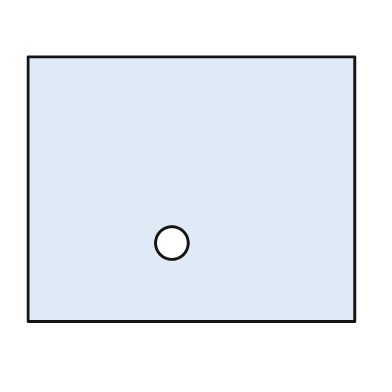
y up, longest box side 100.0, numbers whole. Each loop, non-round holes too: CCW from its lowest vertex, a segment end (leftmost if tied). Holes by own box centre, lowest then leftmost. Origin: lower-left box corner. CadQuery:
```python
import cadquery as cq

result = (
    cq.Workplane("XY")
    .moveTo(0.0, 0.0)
    .lineTo(100.0, 0.0)
    .lineTo(100.0, 81.0)
    .lineTo(0.0, 81.0)
    .close()
    .moveTo(44.0, 24.0)
    .circle(5.0)
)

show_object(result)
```